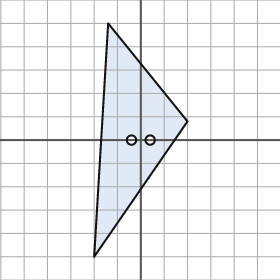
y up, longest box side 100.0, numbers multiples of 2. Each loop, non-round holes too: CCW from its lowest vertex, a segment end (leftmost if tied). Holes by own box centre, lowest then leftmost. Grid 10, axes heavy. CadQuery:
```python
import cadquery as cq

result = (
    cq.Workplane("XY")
    .moveTo(-20.0, -50.0)
    .lineTo(20.0, 8.0)
    .lineTo(-14.0, 50.0)
    .close()
    .moveTo(-4.0, 0.0)
    .circle(2.0)
    .moveTo(4.0, 0.0)
    .circle(2.0)
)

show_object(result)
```